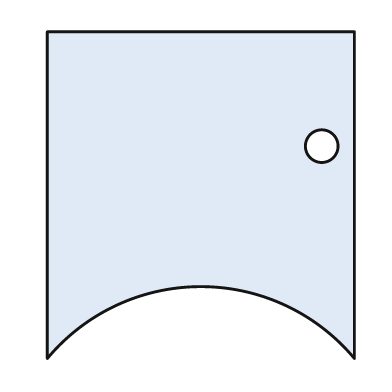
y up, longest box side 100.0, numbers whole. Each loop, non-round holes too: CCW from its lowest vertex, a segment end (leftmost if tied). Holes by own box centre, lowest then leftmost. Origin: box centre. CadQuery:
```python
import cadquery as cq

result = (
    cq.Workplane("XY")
    .moveTo(-47.0, -50.0)
    .threePointArc((0.0, -28.0), (47.0, -50.0))
    .lineTo(47.0, 50.0)
    .lineTo(-47.0, 50.0)
    .close()
    .moveTo(37.0, 15.0)
    .circle(5.0)
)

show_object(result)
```